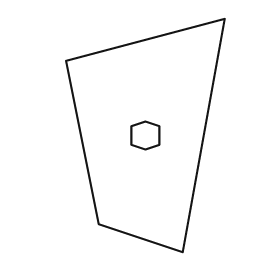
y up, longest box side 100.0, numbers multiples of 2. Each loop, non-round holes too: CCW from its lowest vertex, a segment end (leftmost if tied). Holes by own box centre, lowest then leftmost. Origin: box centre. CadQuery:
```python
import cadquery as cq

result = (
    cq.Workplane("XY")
    .moveTo(16.0, -50.0)
    .lineTo(34.0, 50.0)
    .lineTo(-34.0, 32.0)
    .lineTo(-20.0, -38.0)
    .close()
    .moveTo(0.0, -6.0)
    .lineTo(6.0, -4.0)
    .lineTo(6.0, 4.0)
    .lineTo(0.0, 6.0)
    .lineTo(-6.0, 4.0)
    .lineTo(-6.0, -4.0)
    .close()
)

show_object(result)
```